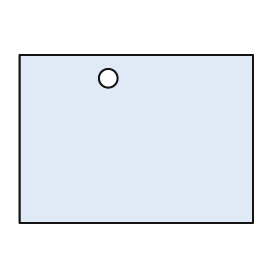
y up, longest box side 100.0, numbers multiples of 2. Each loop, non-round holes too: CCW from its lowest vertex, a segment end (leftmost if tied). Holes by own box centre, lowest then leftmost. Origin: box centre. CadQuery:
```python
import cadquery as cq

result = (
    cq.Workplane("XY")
    .moveTo(-50.0, -36.0)
    .lineTo(50.0, -36.0)
    .lineTo(50.0, 36.0)
    .lineTo(-50.0, 36.0)
    .close()
    .moveTo(-12.0, 26.0)
    .circle(4.0)
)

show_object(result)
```